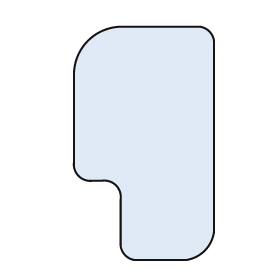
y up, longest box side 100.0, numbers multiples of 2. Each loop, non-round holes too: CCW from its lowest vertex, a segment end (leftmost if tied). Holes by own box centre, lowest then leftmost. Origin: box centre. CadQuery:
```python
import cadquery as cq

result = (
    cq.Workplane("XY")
    .moveTo(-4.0, -50.0)
    .lineTo(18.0, -50.0)
    .threePointArc((26.0, -46.0), (30.0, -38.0))
    .lineTo(30.0, 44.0)
    .threePointArc((28.0, 48.0), (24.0, 50.0))
    .lineTo(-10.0, 50.0)
    .threePointArc((-24.0, 44.0), (-30.0, 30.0))
    .lineTo(-30.0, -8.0)
    .threePointArc((-28.0, -14.0), (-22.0, -16.0))
    .lineTo(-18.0, -16.0)
    .threePointArc((-12.0, -18.0), (-10.0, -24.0))
    .lineTo(-10.0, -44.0)
    .threePointArc((-8.0, -48.0), (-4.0, -50.0))
    .close()
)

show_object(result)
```